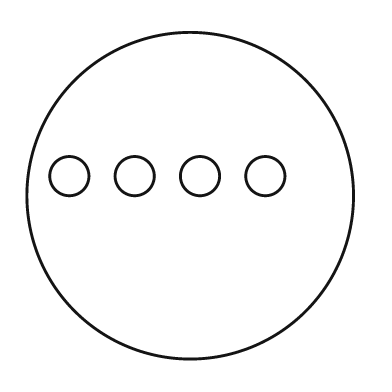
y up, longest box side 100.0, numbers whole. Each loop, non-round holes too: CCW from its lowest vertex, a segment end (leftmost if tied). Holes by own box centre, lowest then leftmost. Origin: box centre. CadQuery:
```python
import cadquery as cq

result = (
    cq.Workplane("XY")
    .moveTo(0.0, 0.0)
    .circle(50.0)
    .moveTo(-37.0, 6.0)
    .circle(6.0)
    .moveTo(-17.0, 6.0)
    .circle(6.0)
    .moveTo(3.0, 6.0)
    .circle(6.0)
    .moveTo(23.0, 6.0)
    .circle(6.0)
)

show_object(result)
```